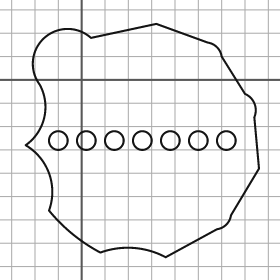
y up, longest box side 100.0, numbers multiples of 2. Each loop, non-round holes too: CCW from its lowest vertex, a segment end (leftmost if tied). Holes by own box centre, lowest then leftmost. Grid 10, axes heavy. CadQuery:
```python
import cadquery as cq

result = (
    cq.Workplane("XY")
    .moveTo(36.0, -76.0)
    .lineTo(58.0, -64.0)
    .threePointArc((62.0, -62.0), (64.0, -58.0))
    .lineTo(76.0, -38.0)
    .lineTo(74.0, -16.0)
    .threePointArc((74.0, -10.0), (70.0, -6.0))
    .lineTo(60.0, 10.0)
    .threePointArc((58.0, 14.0), (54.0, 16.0))
    .lineTo(32.0, 24.0)
    .lineTo(4.0, 18.0)
    .threePointArc((-16.0, 18.0), (-18.0, -2.0))
    .threePointArc((-16.0, -16.0), (-24.0, -28.0))
    .threePointArc((-14.0, -40.0), (-14.0, -56.0))
    .threePointArc((-4.0, -66.0), (8.0, -74.0))
    .threePointArc((22.0, -72.0), (36.0, -76.0))
    .close()
    .moveTo(-10.0, -26.0)
    .circle(4.0)
    .moveTo(2.0, -26.0)
    .circle(4.0)
    .moveTo(14.0, -26.0)
    .circle(4.0)
    .moveTo(26.0, -26.0)
    .circle(4.0)
    .moveTo(38.0, -26.0)
    .circle(4.0)
    .moveTo(50.0, -26.0)
    .circle(4.0)
    .moveTo(62.0, -26.0)
    .circle(4.0)
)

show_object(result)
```